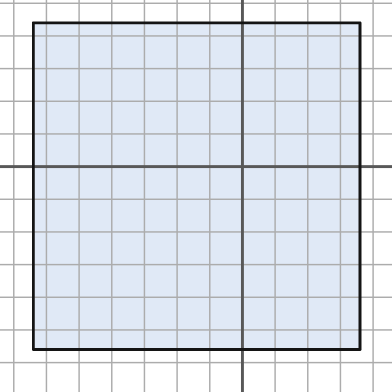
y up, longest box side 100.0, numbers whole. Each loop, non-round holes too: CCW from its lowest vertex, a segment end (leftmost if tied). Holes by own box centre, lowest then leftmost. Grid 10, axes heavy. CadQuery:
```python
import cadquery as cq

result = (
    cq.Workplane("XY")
    .moveTo(-64.0, -56.0)
    .lineTo(36.0, -56.0)
    .lineTo(36.0, 44.0)
    .lineTo(-64.0, 44.0)
    .close()
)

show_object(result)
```